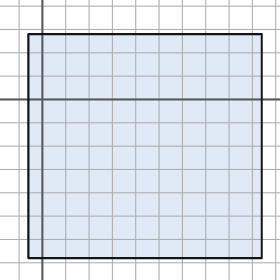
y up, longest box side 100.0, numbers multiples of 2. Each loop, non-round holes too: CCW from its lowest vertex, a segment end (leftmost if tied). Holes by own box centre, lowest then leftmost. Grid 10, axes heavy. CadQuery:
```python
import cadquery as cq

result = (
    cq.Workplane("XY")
    .moveTo(-6.0, -68.0)
    .lineTo(94.0, -68.0)
    .lineTo(94.0, 28.0)
    .lineTo(-6.0, 28.0)
    .close()
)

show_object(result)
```